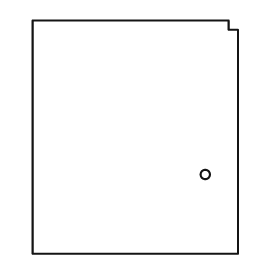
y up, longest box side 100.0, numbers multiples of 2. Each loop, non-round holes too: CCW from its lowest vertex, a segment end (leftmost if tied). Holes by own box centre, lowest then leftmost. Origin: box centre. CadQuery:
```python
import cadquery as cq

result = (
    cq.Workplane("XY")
    .moveTo(-44.0, -50.0)
    .lineTo(44.0, -50.0)
    .lineTo(44.0, 46.0)
    .lineTo(40.0, 46.0)
    .lineTo(40.0, 50.0)
    .lineTo(-44.0, 50.0)
    .close()
    .moveTo(30.0, -16.0)
    .circle(2.0)
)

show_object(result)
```